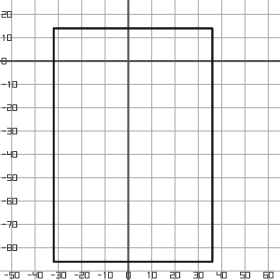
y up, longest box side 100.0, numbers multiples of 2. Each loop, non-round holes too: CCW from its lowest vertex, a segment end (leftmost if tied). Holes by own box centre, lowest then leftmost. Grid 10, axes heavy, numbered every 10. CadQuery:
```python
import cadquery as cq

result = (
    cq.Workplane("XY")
    .moveTo(-32.0, -86.0)
    .lineTo(36.0, -86.0)
    .lineTo(36.0, 14.0)
    .lineTo(-32.0, 14.0)
    .close()
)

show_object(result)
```